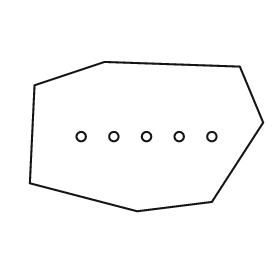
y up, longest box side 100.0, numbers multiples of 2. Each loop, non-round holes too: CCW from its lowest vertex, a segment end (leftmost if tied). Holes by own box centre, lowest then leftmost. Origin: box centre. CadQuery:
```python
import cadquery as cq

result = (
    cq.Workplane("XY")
    .moveTo(-4.0, -32.0)
    .lineTo(28.0, -28.0)
    .lineTo(50.0, 6.0)
    .lineTo(40.0, 30.0)
    .lineTo(-18.0, 32.0)
    .lineTo(-48.0, 22.0)
    .lineTo(-50.0, -20.0)
    .close()
    .moveTo(-28.0, 0.0)
    .circle(2.0)
    .moveTo(-14.0, 0.0)
    .circle(2.0)
    .moveTo(0.0, 0.0)
    .circle(2.0)
    .moveTo(14.0, 0.0)
    .circle(2.0)
    .moveTo(28.0, 0.0)
    .circle(2.0)
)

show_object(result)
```